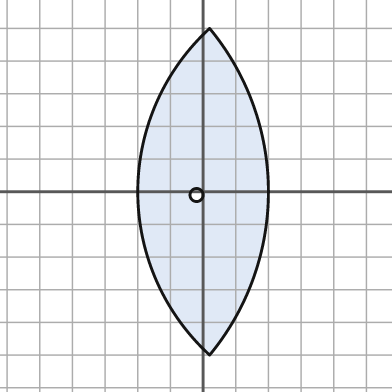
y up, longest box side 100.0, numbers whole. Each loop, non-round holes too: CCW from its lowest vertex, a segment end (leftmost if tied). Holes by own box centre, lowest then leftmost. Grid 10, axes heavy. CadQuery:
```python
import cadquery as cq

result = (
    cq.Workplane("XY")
    .moveTo(2.0, -50.0)
    .threePointArc((20.0, 0.0), (2.0, 50.0))
    .threePointArc((-20.0, 0.0), (2.0, -50.0))
    .close()
    .moveTo(-2.0, -1.0)
    .circle(2.0)
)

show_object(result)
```